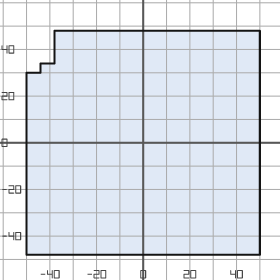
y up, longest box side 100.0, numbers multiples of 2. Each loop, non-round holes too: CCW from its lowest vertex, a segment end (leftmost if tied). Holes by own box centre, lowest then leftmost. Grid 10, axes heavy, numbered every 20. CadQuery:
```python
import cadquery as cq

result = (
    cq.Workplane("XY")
    .moveTo(-50.0, -48.0)
    .lineTo(50.0, -48.0)
    .lineTo(50.0, 48.0)
    .lineTo(-38.0, 48.0)
    .lineTo(-38.0, 34.0)
    .lineTo(-44.0, 34.0)
    .lineTo(-44.0, 30.0)
    .lineTo(-50.0, 30.0)
    .close()
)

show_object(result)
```